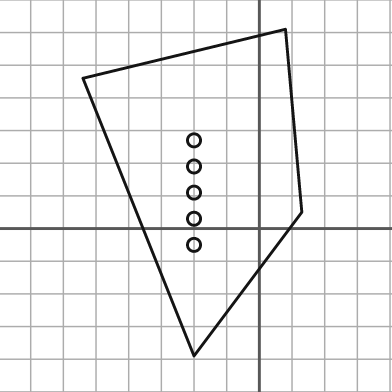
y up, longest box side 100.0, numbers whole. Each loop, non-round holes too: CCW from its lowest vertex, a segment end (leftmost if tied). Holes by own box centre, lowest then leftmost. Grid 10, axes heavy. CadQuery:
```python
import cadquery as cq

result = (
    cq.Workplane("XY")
    .moveTo(-20.0, -39.0)
    .lineTo(13.0, 5.0)
    .lineTo(8.0, 61.0)
    .lineTo(-54.0, 46.0)
    .close()
    .moveTo(-20.0, -5.0)
    .circle(2.0)
    .moveTo(-20.0, 3.0)
    .circle(2.0)
    .moveTo(-20.0, 11.0)
    .circle(2.0)
    .moveTo(-20.0, 19.0)
    .circle(2.0)
    .moveTo(-20.0, 27.0)
    .circle(2.0)
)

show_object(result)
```